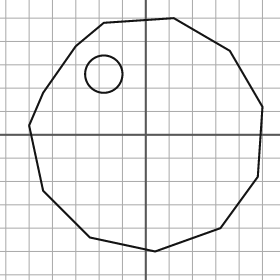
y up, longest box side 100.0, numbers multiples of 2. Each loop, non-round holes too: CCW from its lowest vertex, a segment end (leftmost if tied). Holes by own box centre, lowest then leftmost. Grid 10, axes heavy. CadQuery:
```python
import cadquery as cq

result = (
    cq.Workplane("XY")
    .moveTo(4.0, -50.0)
    .lineTo(32.0, -40.0)
    .lineTo(48.0, -18.0)
    .lineTo(50.0, 12.0)
    .lineTo(36.0, 36.0)
    .lineTo(12.0, 50.0)
    .lineTo(-18.0, 48.0)
    .lineTo(-30.0, 38.0)
    .lineTo(-44.0, 18.0)
    .lineTo(-50.0, 4.0)
    .lineTo(-44.0, -24.0)
    .lineTo(-24.0, -44.0)
    .close()
    .moveTo(-18.0, 26.0)
    .circle(8.0)
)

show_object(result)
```